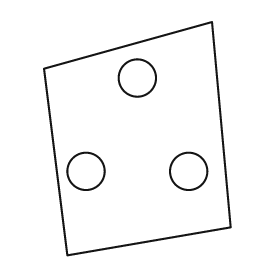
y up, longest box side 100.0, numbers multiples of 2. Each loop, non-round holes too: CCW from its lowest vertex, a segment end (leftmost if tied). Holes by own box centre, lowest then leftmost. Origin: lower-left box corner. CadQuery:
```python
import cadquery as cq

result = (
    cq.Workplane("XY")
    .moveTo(10.0, 0.0)
    .lineTo(80.0, 12.0)
    .lineTo(72.0, 100.0)
    .lineTo(0.0, 80.0)
    .close()
    .moveTo(18.0, 36.0)
    .circle(8.0)
    .moveTo(62.0, 36.0)
    .circle(8.0)
    .moveTo(40.0, 76.0)
    .circle(8.0)
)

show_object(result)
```